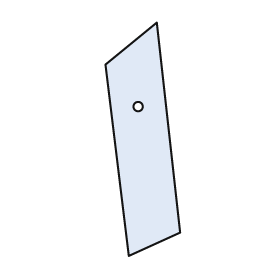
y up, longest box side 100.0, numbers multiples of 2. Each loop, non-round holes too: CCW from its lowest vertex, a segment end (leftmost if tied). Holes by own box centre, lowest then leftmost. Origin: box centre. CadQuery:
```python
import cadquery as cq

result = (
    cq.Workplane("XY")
    .moveTo(-6.0, -50.0)
    .lineTo(16.0, -40.0)
    .lineTo(6.0, 50.0)
    .lineTo(-16.0, 32.0)
    .close()
    .moveTo(-2.0, 14.0)
    .circle(2.0)
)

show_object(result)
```